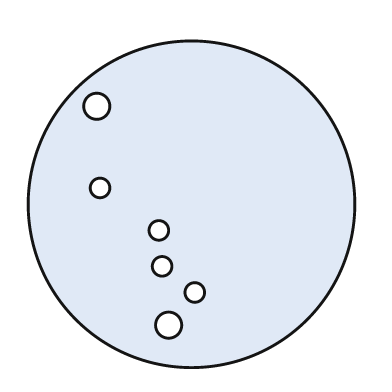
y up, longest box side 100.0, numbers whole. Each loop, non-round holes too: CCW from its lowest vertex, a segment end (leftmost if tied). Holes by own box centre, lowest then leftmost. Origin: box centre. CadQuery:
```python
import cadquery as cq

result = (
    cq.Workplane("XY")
    .moveTo(0.0, 0.0)
    .circle(50.0)
    .moveTo(-7.0, -37.0)
    .circle(4.0)
    .moveTo(1.0, -27.0)
    .circle(3.0)
    .moveTo(-9.0, -19.0)
    .circle(3.0)
    .moveTo(-10.0, -8.0)
    .circle(3.0)
    .moveTo(-28.0, 5.0)
    .circle(3.0)
    .moveTo(-29.0, 30.0)
    .circle(4.0)
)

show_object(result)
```